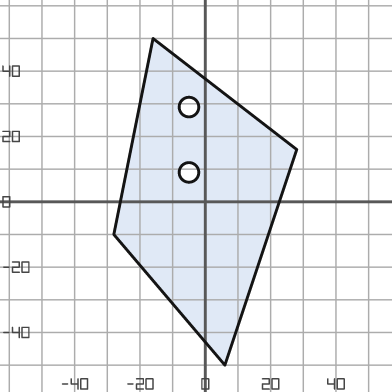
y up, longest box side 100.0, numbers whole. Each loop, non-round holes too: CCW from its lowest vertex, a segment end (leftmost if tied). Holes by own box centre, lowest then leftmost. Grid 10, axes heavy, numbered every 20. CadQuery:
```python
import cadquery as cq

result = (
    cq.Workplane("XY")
    .moveTo(6.0, -50.0)
    .lineTo(28.0, 16.0)
    .lineTo(-16.0, 50.0)
    .lineTo(-28.0, -10.0)
    .close()
    .moveTo(-5.0, 9.0)
    .circle(3.0)
    .moveTo(-5.0, 29.0)
    .circle(3.0)
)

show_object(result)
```